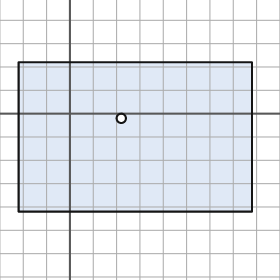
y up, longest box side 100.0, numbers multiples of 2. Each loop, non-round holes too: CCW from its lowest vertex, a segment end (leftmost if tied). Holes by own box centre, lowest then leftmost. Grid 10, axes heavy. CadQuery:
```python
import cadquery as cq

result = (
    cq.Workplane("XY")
    .moveTo(-22.0, -42.0)
    .lineTo(78.0, -42.0)
    .lineTo(78.0, 22.0)
    .lineTo(-22.0, 22.0)
    .close()
    .moveTo(22.0, -2.0)
    .circle(2.0)
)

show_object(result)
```